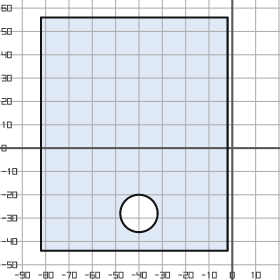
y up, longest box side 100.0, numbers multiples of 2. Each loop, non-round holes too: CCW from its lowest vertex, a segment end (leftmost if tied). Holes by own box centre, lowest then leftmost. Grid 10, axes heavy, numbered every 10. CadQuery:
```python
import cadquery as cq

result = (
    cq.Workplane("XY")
    .moveTo(-82.0, -44.0)
    .lineTo(-2.0, -44.0)
    .lineTo(-2.0, 56.0)
    .lineTo(-82.0, 56.0)
    .close()
    .moveTo(-40.0, -28.0)
    .circle(8.0)
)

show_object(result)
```